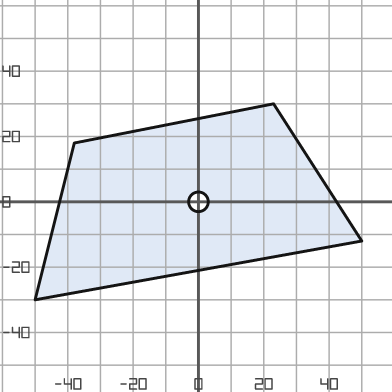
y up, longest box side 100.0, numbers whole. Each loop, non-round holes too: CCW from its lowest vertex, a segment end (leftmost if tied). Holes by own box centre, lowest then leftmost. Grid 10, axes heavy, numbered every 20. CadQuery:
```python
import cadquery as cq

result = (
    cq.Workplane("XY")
    .moveTo(-50.0, -30.0)
    .lineTo(50.0, -12.0)
    .lineTo(23.0, 30.0)
    .lineTo(-38.0, 18.0)
    .close()
    .moveTo(0.0, 0.0)
    .circle(3.0)
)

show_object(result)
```